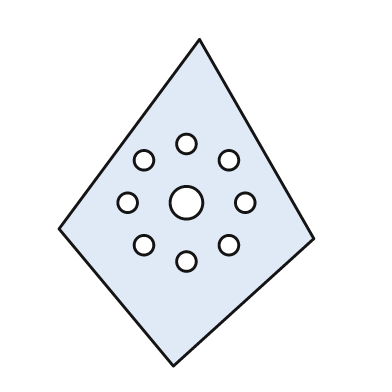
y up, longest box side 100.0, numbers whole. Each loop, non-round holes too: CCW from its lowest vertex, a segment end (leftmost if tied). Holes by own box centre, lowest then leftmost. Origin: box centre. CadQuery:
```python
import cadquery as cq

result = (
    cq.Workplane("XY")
    .moveTo(-4.0, -50.0)
    .lineTo(39.0, -11.0)
    .lineTo(4.0, 50.0)
    .lineTo(-39.0, -8.0)
    .close()
    .moveTo(0.0, -18.0)
    .circle(3.0)
    .moveTo(-13.0, -13.0)
    .circle(3.0)
    .moveTo(13.0, -13.0)
    .circle(3.0)
    .moveTo(-18.0, 0.0)
    .circle(3.0)
    .moveTo(0.0, 0.0)
    .circle(5.0)
    .moveTo(18.0, 0.0)
    .circle(3.0)
    .moveTo(-13.0, 13.0)
    .circle(3.0)
    .moveTo(13.0, 13.0)
    .circle(3.0)
    .moveTo(0.0, 18.0)
    .circle(3.0)
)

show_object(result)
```